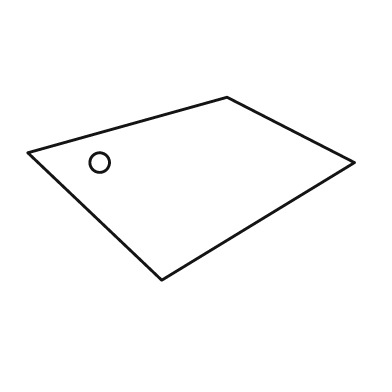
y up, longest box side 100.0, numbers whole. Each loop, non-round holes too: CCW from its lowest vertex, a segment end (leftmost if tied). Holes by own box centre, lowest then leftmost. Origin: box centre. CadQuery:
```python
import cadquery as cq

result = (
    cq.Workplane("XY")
    .moveTo(-9.0, -28.0)
    .lineTo(50.0, 8.0)
    .lineTo(11.0, 28.0)
    .lineTo(-50.0, 11.0)
    .close()
    .moveTo(-28.0, 8.0)
    .circle(3.0)
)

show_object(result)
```